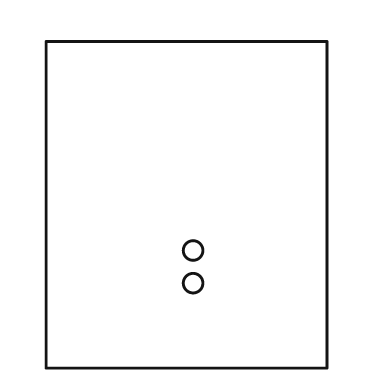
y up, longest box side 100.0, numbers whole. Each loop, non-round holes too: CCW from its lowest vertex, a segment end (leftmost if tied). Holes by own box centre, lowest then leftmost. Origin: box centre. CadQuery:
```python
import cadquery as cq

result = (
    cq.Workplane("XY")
    .moveTo(-43.0, -50.0)
    .lineTo(43.0, -50.0)
    .lineTo(43.0, 50.0)
    .lineTo(-43.0, 50.0)
    .close()
    .moveTo(2.0, -24.0)
    .circle(3.0)
    .moveTo(2.0, -14.0)
    .circle(3.0)
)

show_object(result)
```